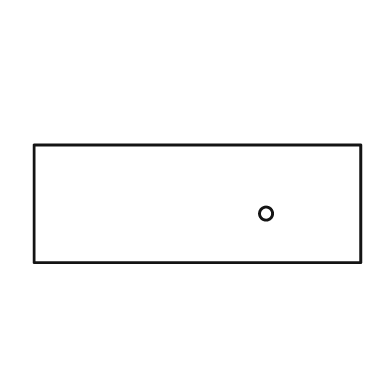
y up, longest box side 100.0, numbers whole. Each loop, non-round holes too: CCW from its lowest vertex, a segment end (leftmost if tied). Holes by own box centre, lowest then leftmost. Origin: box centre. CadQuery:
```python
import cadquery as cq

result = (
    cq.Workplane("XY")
    .moveTo(-50.0, -18.0)
    .lineTo(50.0, -18.0)
    .lineTo(50.0, 18.0)
    .lineTo(-50.0, 18.0)
    .close()
    .moveTo(21.0, -3.0)
    .circle(2.0)
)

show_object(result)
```